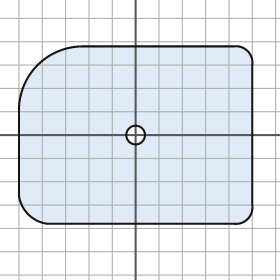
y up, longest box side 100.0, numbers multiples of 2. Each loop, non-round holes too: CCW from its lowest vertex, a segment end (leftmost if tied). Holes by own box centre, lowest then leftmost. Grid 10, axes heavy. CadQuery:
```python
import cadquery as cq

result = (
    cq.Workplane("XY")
    .moveTo(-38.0, -38.0)
    .lineTo(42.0, -38.0)
    .threePointArc((48.0, -36.0), (50.0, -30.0))
    .lineTo(50.0, 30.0)
    .threePointArc((48.0, 36.0), (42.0, 38.0))
    .lineTo(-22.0, 38.0)
    .threePointArc((-42.0, 30.0), (-50.0, 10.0))
    .lineTo(-50.0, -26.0)
    .threePointArc((-46.0, -34.0), (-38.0, -38.0))
    .close()
    .moveTo(0.0, 0.0)
    .circle(4.0)
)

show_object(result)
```